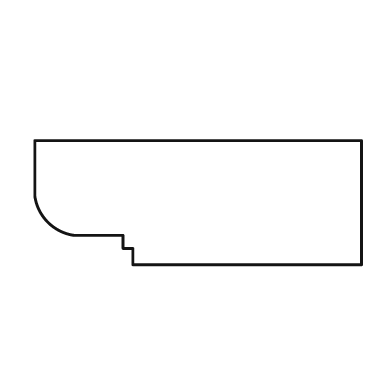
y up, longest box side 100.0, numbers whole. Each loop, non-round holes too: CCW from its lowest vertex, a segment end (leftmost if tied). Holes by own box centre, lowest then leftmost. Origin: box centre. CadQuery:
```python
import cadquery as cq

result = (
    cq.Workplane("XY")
    .moveTo(-20.0, -19.0)
    .lineTo(50.0, -19.0)
    .lineTo(50.0, 19.0)
    .lineTo(-50.0, 19.0)
    .lineTo(-50.0, 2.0)
    .threePointArc((-46.0, -6.0), (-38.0, -10.0))
    .lineTo(-23.0, -10.0)
    .lineTo(-23.0, -14.0)
    .lineTo(-20.0, -14.0)
    .close()
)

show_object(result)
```